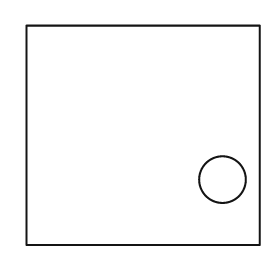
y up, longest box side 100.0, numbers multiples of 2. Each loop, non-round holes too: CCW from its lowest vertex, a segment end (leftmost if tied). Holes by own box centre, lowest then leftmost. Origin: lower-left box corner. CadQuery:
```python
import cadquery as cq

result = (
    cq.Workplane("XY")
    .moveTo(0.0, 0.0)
    .lineTo(100.0, 0.0)
    .lineTo(100.0, 94.0)
    .lineTo(0.0, 94.0)
    .close()
    .moveTo(84.0, 28.0)
    .circle(10.0)
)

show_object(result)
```